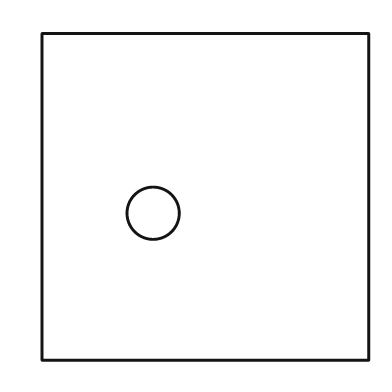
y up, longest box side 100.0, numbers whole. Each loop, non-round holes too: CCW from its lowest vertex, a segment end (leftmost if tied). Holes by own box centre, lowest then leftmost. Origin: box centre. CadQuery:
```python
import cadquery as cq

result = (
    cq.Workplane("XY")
    .moveTo(-50.0, -50.0)
    .lineTo(50.0, -50.0)
    .lineTo(50.0, 50.0)
    .lineTo(-50.0, 50.0)
    .close()
    .moveTo(-16.0, -5.0)
    .circle(8.0)
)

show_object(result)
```